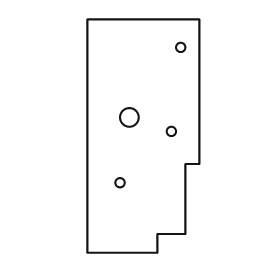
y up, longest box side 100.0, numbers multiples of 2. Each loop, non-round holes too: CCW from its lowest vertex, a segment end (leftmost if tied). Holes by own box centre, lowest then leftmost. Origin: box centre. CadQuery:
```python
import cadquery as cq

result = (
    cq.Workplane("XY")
    .moveTo(-24.0, -50.0)
    .lineTo(6.0, -50.0)
    .lineTo(6.0, -42.0)
    .lineTo(18.0, -42.0)
    .lineTo(18.0, -12.0)
    .lineTo(24.0, -12.0)
    .lineTo(24.0, 50.0)
    .lineTo(-24.0, 50.0)
    .close()
    .moveTo(-10.0, -20.0)
    .circle(2.0)
    .moveTo(12.0, 2.0)
    .circle(2.0)
    .moveTo(-6.0, 8.0)
    .circle(4.0)
    .moveTo(16.0, 38.0)
    .circle(2.0)
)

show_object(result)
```